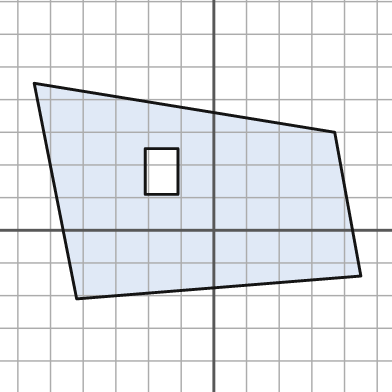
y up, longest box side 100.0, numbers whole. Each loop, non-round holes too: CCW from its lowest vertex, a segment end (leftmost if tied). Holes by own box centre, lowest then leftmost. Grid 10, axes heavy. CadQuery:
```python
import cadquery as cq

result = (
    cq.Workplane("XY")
    .moveTo(-42.0, -21.0)
    .lineTo(45.0, -14.0)
    .lineTo(37.0, 30.0)
    .lineTo(-55.0, 45.0)
    .close()
    .moveTo(-21.0, 11.0)
    .lineTo(-11.0, 11.0)
    .lineTo(-11.0, 25.0)
    .lineTo(-21.0, 25.0)
    .close()
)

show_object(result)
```